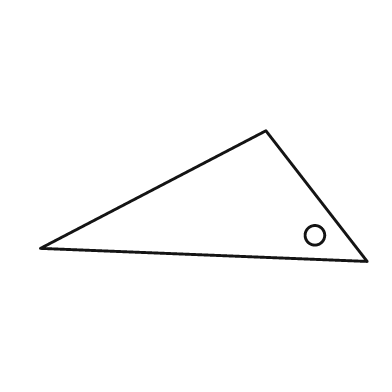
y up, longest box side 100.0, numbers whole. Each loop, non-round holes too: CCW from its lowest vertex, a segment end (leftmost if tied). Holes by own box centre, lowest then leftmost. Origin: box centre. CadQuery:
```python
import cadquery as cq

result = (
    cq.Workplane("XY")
    .moveTo(50.0, -20.0)
    .lineTo(19.0, 20.0)
    .lineTo(-50.0, -16.0)
    .close()
    .moveTo(34.0, -12.0)
    .circle(3.0)
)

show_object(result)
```